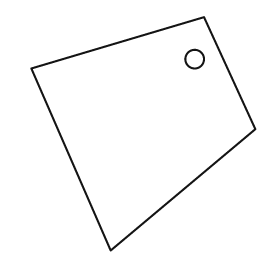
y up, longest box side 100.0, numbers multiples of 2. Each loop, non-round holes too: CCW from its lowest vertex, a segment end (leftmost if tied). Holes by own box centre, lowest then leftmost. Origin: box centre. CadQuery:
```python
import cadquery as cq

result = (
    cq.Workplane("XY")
    .moveTo(-14.0, -50.0)
    .lineTo(48.0, 2.0)
    .lineTo(26.0, 50.0)
    .lineTo(-48.0, 28.0)
    .close()
    .moveTo(22.0, 32.0)
    .circle(4.0)
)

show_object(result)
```